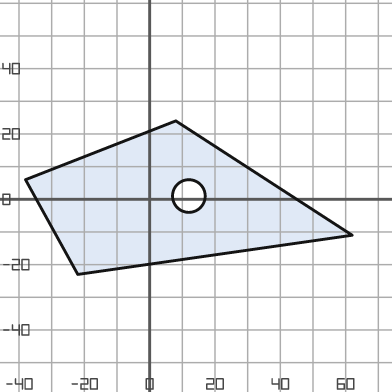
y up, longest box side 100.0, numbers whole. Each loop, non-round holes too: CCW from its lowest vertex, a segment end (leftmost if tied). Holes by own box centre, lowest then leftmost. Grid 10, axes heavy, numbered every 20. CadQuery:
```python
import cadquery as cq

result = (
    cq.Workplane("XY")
    .moveTo(-22.0, -23.0)
    .lineTo(62.0, -11.0)
    .lineTo(8.0, 24.0)
    .lineTo(-38.0, 6.0)
    .close()
    .moveTo(12.0, 1.0)
    .circle(5.0)
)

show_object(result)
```